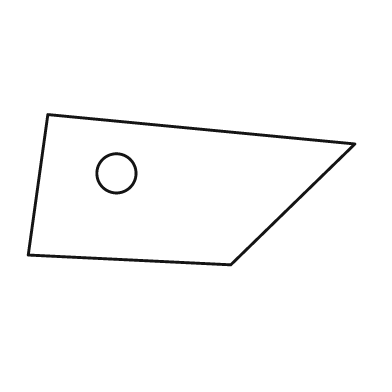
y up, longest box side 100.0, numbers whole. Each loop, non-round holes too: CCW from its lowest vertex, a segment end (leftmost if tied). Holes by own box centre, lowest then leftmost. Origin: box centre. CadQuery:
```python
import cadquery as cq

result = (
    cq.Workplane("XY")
    .moveTo(12.0, -23.0)
    .lineTo(50.0, 14.0)
    .lineTo(-44.0, 23.0)
    .lineTo(-50.0, -20.0)
    .close()
    .moveTo(-23.0, 5.0)
    .circle(6.0)
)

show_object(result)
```